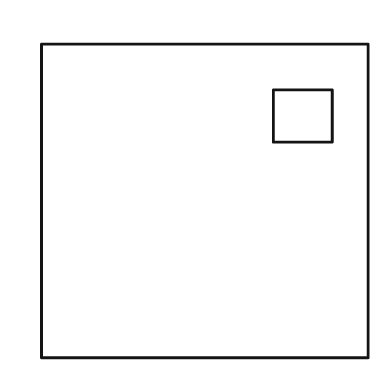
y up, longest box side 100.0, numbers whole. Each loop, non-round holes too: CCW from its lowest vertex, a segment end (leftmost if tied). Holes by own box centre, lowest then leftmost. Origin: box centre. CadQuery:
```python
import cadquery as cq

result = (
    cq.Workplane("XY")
    .moveTo(-50.0, -48.0)
    .lineTo(50.0, -48.0)
    .lineTo(50.0, 48.0)
    .lineTo(-50.0, 48.0)
    .close()
    .moveTo(21.0, 18.0)
    .lineTo(39.0, 18.0)
    .lineTo(39.0, 34.0)
    .lineTo(21.0, 34.0)
    .close()
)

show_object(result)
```